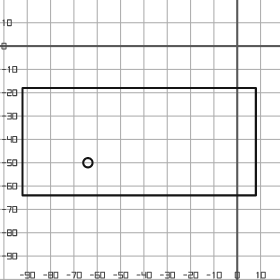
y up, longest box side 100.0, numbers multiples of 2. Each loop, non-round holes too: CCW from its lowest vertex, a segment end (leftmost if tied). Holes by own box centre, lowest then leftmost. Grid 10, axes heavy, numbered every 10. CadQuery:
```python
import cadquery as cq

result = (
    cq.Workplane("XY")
    .moveTo(-92.0, -64.0)
    .lineTo(8.0, -64.0)
    .lineTo(8.0, -18.0)
    .lineTo(-92.0, -18.0)
    .close()
    .moveTo(-64.0, -50.0)
    .circle(2.0)
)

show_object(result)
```